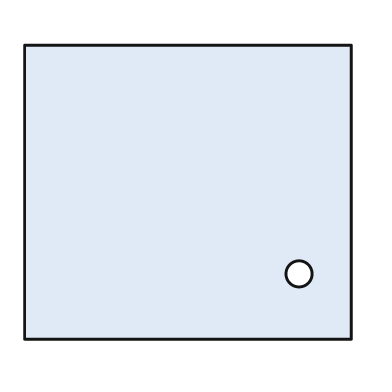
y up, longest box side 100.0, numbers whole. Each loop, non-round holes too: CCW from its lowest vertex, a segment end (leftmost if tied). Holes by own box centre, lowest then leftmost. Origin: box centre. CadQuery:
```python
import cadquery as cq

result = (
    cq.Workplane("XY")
    .moveTo(-50.0, -45.0)
    .lineTo(50.0, -45.0)
    .lineTo(50.0, 45.0)
    .lineTo(-50.0, 45.0)
    .close()
    .moveTo(34.0, -25.0)
    .circle(4.0)
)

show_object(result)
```